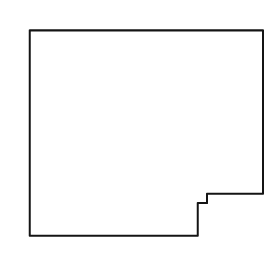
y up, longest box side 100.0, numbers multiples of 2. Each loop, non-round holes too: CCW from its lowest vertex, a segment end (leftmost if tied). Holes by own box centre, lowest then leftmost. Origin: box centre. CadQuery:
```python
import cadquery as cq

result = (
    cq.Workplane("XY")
    .moveTo(-50.0, -44.0)
    .lineTo(22.0, -44.0)
    .lineTo(22.0, -30.0)
    .lineTo(26.0, -30.0)
    .lineTo(26.0, -26.0)
    .lineTo(50.0, -26.0)
    .lineTo(50.0, 44.0)
    .lineTo(-50.0, 44.0)
    .close()
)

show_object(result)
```